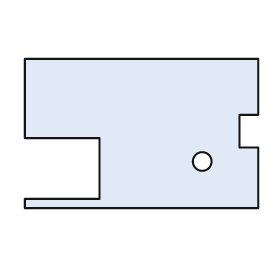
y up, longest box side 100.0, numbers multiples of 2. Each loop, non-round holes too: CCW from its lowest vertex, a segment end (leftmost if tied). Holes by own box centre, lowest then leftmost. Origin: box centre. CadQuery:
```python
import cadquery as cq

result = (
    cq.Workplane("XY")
    .moveTo(-50.0, -32.0)
    .lineTo(50.0, -32.0)
    .lineTo(50.0, -6.0)
    .lineTo(42.0, -6.0)
    .lineTo(42.0, 8.0)
    .lineTo(50.0, 8.0)
    .lineTo(50.0, 32.0)
    .lineTo(-50.0, 32.0)
    .lineTo(-50.0, -2.0)
    .lineTo(-18.0, -2.0)
    .lineTo(-18.0, -28.0)
    .lineTo(-50.0, -28.0)
    .close()
    .moveTo(26.0, -12.0)
    .circle(4.0)
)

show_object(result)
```